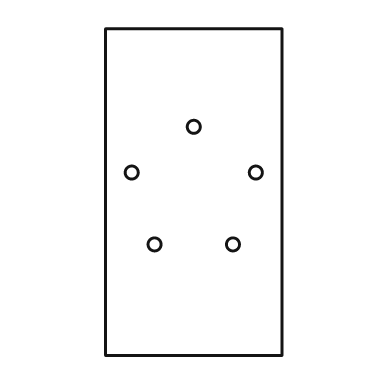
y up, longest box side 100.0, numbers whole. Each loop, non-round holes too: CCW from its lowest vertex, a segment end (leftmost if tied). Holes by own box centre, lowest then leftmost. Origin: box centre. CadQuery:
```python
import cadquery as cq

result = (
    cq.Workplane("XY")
    .moveTo(-27.0, -50.0)
    .lineTo(27.0, -50.0)
    .lineTo(27.0, 50.0)
    .lineTo(-27.0, 50.0)
    .close()
    .moveTo(-12.0, -16.0)
    .circle(2.0)
    .moveTo(12.0, -16.0)
    .circle(2.0)
    .moveTo(-19.0, 6.0)
    .circle(2.0)
    .moveTo(19.0, 6.0)
    .circle(2.0)
    .moveTo(0.0, 20.0)
    .circle(2.0)
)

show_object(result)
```